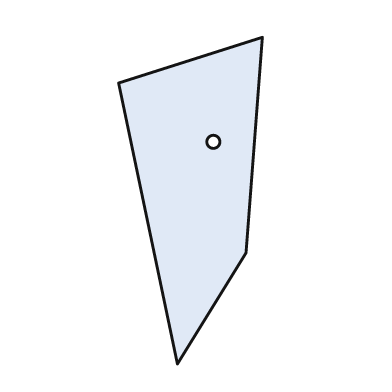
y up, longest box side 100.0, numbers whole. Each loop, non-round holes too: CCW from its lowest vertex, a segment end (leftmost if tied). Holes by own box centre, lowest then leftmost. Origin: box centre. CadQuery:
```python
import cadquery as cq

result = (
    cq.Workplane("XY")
    .moveTo(-4.0, -50.0)
    .lineTo(17.0, -16.0)
    .lineTo(22.0, 50.0)
    .lineTo(-22.0, 36.0)
    .close()
    .moveTo(7.0, 18.0)
    .circle(2.0)
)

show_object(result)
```